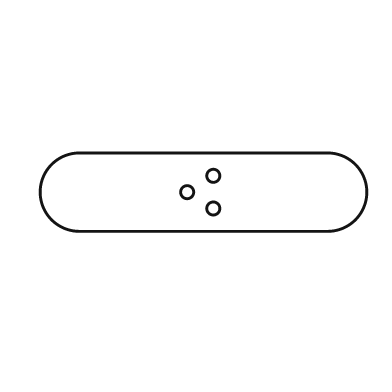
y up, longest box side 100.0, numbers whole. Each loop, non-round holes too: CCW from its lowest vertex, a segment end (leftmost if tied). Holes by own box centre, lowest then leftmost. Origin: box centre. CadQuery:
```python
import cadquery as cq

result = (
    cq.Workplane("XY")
    .moveTo(-38.0, -12.0)
    .lineTo(38.0, -12.0)
    .threePointArc((50.0, 0.0), (38.0, 12.0))
    .lineTo(-38.0, 12.0)
    .threePointArc((-50.0, 0.0), (-38.0, -12.0))
    .close()
    .moveTo(3.0, -5.0)
    .circle(2.0)
    .moveTo(-5.0, 0.0)
    .circle(2.0)
    .moveTo(3.0, 5.0)
    .circle(2.0)
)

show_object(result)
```